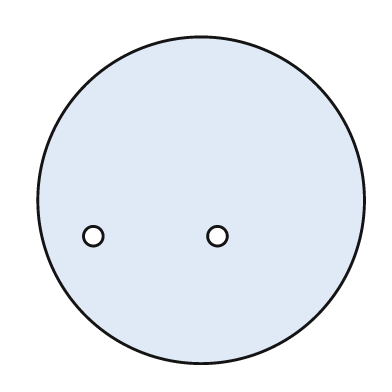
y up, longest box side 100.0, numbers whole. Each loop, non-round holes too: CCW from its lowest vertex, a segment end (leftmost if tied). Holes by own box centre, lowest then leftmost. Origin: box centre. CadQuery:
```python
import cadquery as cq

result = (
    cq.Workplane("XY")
    .moveTo(0.0, 0.0)
    .circle(50.0)
    .moveTo(-33.0, -11.0)
    .circle(3.0)
    .moveTo(5.0, -11.0)
    .circle(3.0)
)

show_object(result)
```